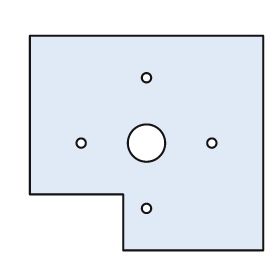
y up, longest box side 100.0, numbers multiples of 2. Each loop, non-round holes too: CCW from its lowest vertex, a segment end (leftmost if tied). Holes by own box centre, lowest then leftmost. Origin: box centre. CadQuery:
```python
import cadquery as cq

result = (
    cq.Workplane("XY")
    .moveTo(-10.0, -46.0)
    .lineTo(50.0, -46.0)
    .lineTo(50.0, 46.0)
    .lineTo(-50.0, 46.0)
    .lineTo(-50.0, -22.0)
    .lineTo(-10.0, -22.0)
    .close()
    .moveTo(0.0, -28.0)
    .circle(2.0)
    .moveTo(-28.0, 0.0)
    .circle(2.0)
    .moveTo(0.0, 0.0)
    .circle(8.0)
    .moveTo(28.0, 0.0)
    .circle(2.0)
    .moveTo(0.0, 28.0)
    .circle(2.0)
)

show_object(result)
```